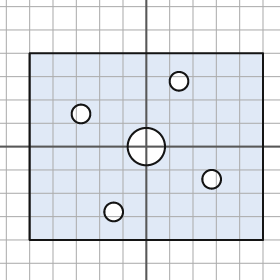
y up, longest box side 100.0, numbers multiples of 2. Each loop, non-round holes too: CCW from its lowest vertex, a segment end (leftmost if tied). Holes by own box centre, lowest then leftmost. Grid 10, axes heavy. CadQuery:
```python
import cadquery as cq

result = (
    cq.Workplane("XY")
    .moveTo(-50.0, -40.0)
    .lineTo(50.0, -40.0)
    .lineTo(50.0, 40.0)
    .lineTo(-50.0, 40.0)
    .close()
    .moveTo(-14.0, -28.0)
    .circle(4.0)
    .moveTo(28.0, -14.0)
    .circle(4.0)
    .moveTo(0.0, 0.0)
    .circle(8.0)
    .moveTo(-28.0, 14.0)
    .circle(4.0)
    .moveTo(14.0, 28.0)
    .circle(4.0)
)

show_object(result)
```